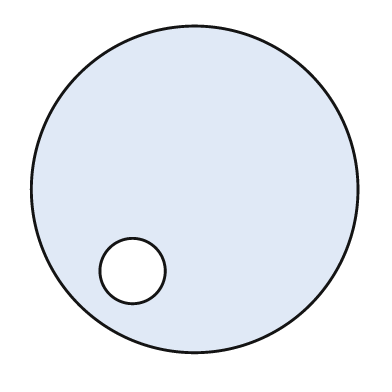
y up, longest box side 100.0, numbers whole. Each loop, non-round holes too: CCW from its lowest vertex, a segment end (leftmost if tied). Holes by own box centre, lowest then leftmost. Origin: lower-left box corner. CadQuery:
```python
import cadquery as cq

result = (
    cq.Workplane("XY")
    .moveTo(50.0, 50.0)
    .circle(50.0)
    .moveTo(31.0, 25.0)
    .circle(10.0)
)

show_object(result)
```